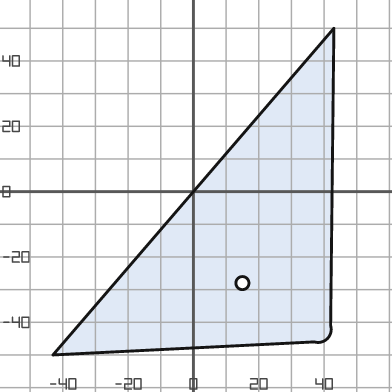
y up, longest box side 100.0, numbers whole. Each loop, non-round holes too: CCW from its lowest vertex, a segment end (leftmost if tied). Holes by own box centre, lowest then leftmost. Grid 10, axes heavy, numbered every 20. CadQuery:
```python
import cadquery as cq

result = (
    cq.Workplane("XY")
    .moveTo(-43.0, -50.0)
    .lineTo(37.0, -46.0)
    .threePointArc((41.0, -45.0), (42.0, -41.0))
    .lineTo(43.0, 50.0)
    .close()
    .moveTo(15.0, -28.0)
    .circle(2.0)
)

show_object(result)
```